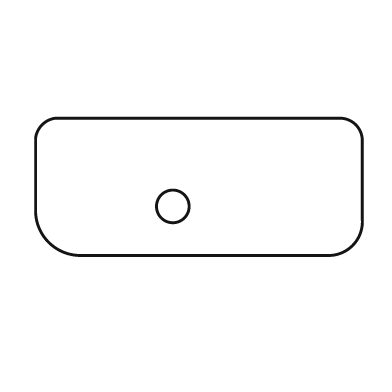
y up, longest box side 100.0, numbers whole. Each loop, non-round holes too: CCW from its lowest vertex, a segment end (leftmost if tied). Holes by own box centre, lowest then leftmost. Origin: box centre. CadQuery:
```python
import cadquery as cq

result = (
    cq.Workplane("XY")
    .moveTo(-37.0, -21.0)
    .lineTo(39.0, -21.0)
    .threePointArc((47.0, -18.0), (50.0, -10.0))
    .lineTo(50.0, 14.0)
    .threePointArc((48.0, 19.0), (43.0, 21.0))
    .lineTo(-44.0, 21.0)
    .threePointArc((-48.0, 19.0), (-50.0, 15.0))
    .lineTo(-50.0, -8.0)
    .threePointArc((-46.0, -17.0), (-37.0, -21.0))
    .close()
    .moveTo(-8.0, -6.0)
    .circle(5.0)
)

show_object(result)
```